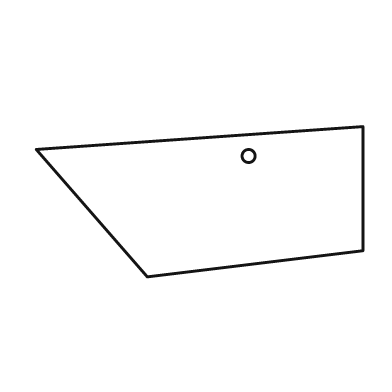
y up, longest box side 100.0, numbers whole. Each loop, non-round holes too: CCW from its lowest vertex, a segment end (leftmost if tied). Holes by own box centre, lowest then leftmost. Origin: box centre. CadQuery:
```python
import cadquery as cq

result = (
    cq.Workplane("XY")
    .moveTo(-16.0, -23.0)
    .lineTo(50.0, -15.0)
    .lineTo(50.0, 23.0)
    .lineTo(-50.0, 16.0)
    .close()
    .moveTo(15.0, 14.0)
    .circle(2.0)
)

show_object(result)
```